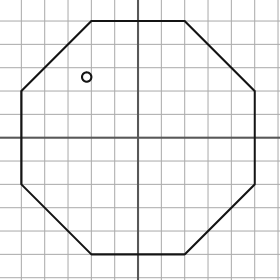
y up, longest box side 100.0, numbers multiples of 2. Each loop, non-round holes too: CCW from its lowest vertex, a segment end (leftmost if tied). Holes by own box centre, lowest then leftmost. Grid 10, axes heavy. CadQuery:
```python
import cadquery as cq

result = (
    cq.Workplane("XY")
    .moveTo(-20.0, -50.0)
    .lineTo(20.0, -50.0)
    .lineTo(50.0, -20.0)
    .lineTo(50.0, 20.0)
    .lineTo(20.0, 50.0)
    .lineTo(-20.0, 50.0)
    .lineTo(-50.0, 20.0)
    .lineTo(-50.0, -20.0)
    .close()
    .moveTo(-22.0, 26.0)
    .circle(2.0)
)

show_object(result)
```